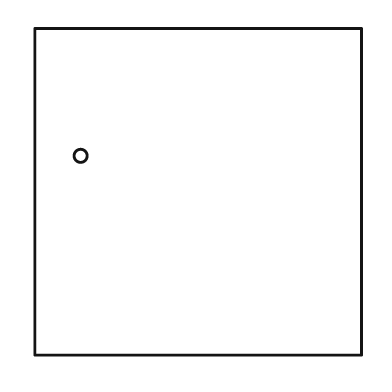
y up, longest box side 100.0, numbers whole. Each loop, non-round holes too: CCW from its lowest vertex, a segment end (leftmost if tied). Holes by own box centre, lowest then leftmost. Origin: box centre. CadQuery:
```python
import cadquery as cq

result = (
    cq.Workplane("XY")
    .moveTo(-50.0, -50.0)
    .lineTo(50.0, -50.0)
    .lineTo(50.0, 50.0)
    .lineTo(-50.0, 50.0)
    .close()
    .moveTo(-36.0, 11.0)
    .circle(2.0)
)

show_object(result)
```